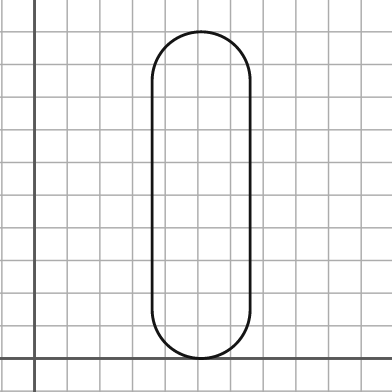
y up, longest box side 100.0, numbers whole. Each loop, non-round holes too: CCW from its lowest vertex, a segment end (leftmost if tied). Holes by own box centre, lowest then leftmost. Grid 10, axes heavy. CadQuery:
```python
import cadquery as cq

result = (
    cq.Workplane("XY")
    .moveTo(36.0, 15.0)
    .threePointArc((51.0, 0.0), (66.0, 15.0))
    .lineTo(66.0, 85.0)
    .threePointArc((51.0, 100.0), (36.0, 85.0))
    .close()
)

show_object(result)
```